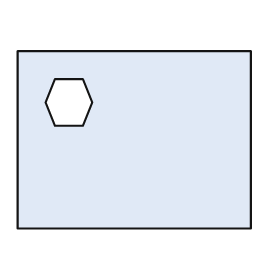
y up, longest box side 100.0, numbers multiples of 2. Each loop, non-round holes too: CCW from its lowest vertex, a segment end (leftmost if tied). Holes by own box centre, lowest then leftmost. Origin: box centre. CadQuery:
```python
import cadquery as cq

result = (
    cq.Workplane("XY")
    .moveTo(-50.0, -38.0)
    .lineTo(50.0, -38.0)
    .lineTo(50.0, 38.0)
    .lineTo(-50.0, 38.0)
    .close()
    .moveTo(-34.0, 6.0)
    .lineTo(-22.0, 6.0)
    .lineTo(-18.0, 16.0)
    .lineTo(-22.0, 26.0)
    .lineTo(-34.0, 26.0)
    .lineTo(-38.0, 16.0)
    .close()
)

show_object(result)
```